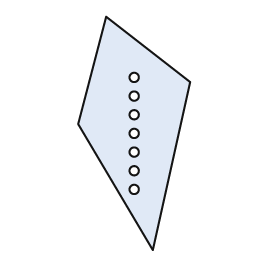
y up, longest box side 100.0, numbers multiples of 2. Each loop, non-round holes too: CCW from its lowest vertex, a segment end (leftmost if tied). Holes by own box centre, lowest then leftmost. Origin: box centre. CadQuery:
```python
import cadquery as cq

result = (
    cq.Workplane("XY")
    .moveTo(8.0, -50.0)
    .lineTo(24.0, 22.0)
    .lineTo(-12.0, 50.0)
    .lineTo(-24.0, 4.0)
    .close()
    .moveTo(0.0, -24.0)
    .circle(2.0)
    .moveTo(0.0, -16.0)
    .circle(2.0)
    .moveTo(0.0, -8.0)
    .circle(2.0)
    .moveTo(0.0, 0.0)
    .circle(2.0)
    .moveTo(0.0, 8.0)
    .circle(2.0)
    .moveTo(0.0, 16.0)
    .circle(2.0)
    .moveTo(0.0, 24.0)
    .circle(2.0)
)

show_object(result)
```